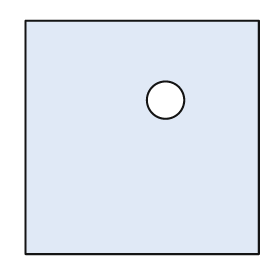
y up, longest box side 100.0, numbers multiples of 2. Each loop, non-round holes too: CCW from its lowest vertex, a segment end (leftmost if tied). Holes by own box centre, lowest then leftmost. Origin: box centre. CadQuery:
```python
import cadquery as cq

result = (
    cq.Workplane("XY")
    .moveTo(-50.0, -50.0)
    .lineTo(50.0, -50.0)
    .lineTo(50.0, 50.0)
    .lineTo(-50.0, 50.0)
    .close()
    .moveTo(10.0, 16.0)
    .circle(8.0)
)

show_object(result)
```